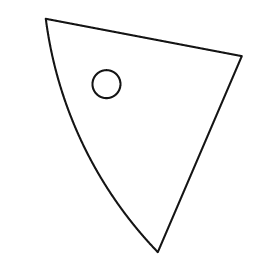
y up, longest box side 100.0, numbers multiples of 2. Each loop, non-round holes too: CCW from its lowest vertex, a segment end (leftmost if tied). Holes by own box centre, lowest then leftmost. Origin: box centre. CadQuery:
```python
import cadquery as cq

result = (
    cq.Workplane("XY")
    .moveTo(6.0, -50.0)
    .lineTo(42.0, 34.0)
    .lineTo(-42.0, 50.0)
    .threePointArc((-26.0, -4.0), (6.0, -50.0))
    .close()
    .moveTo(-16.0, 22.0)
    .circle(6.0)
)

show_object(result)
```